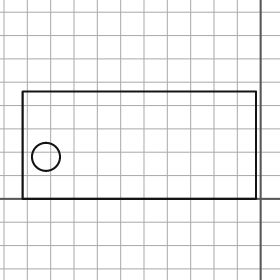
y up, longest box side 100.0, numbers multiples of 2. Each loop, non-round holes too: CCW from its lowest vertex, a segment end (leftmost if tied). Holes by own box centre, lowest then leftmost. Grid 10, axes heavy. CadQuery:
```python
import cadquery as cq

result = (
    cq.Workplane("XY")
    .moveTo(-102.0, 0.0)
    .lineTo(-2.0, 0.0)
    .lineTo(-2.0, 46.0)
    .lineTo(-102.0, 46.0)
    .close()
    .moveTo(-92.0, 18.0)
    .circle(6.0)
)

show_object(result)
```